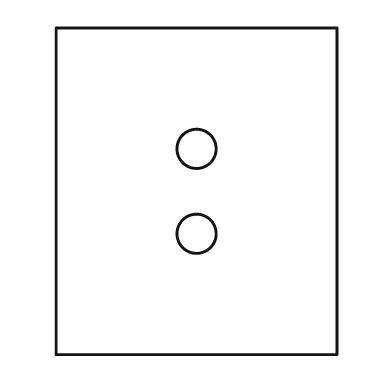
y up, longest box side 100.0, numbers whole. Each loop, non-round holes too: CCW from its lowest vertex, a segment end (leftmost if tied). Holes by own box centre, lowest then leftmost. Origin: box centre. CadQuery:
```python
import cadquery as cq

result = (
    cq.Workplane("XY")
    .moveTo(-43.0, -50.0)
    .lineTo(43.0, -50.0)
    .lineTo(43.0, 50.0)
    .lineTo(-43.0, 50.0)
    .close()
    .moveTo(0.0, -13.0)
    .circle(6.0)
    .moveTo(0.0, 13.0)
    .circle(6.0)
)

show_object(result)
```